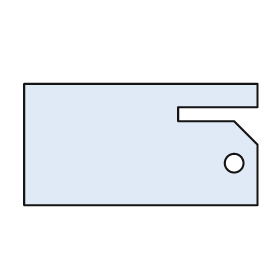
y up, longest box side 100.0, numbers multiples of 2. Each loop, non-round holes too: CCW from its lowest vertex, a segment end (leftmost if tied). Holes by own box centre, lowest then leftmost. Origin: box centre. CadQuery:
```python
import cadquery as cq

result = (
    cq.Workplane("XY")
    .moveTo(-50.0, -26.0)
    .lineTo(50.0, -26.0)
    .lineTo(50.0, 0.0)
    .lineTo(40.0, 10.0)
    .lineTo(16.0, 10.0)
    .lineTo(16.0, 16.0)
    .lineTo(50.0, 16.0)
    .lineTo(50.0, 26.0)
    .lineTo(-50.0, 26.0)
    .close()
    .moveTo(40.0, -8.0)
    .circle(4.0)
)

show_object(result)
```